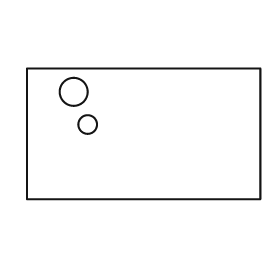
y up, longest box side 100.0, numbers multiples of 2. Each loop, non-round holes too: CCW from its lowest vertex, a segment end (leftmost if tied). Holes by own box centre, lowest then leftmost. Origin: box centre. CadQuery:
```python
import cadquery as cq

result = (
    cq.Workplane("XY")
    .moveTo(-50.0, -28.0)
    .lineTo(50.0, -28.0)
    .lineTo(50.0, 28.0)
    .lineTo(-50.0, 28.0)
    .close()
    .moveTo(-24.0, 4.0)
    .circle(4.0)
    .moveTo(-30.0, 18.0)
    .circle(6.0)
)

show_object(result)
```